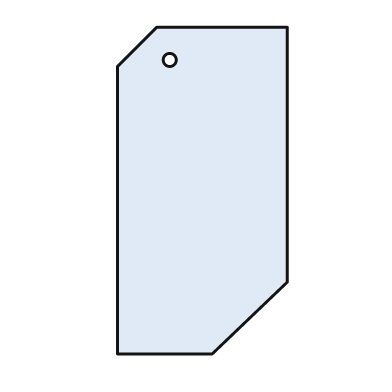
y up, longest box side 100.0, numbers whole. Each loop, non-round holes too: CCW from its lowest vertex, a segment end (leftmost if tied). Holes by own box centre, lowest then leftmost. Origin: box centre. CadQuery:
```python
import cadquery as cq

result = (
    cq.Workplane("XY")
    .moveTo(-26.0, -50.0)
    .lineTo(3.0, -50.0)
    .lineTo(26.0, -28.0)
    .lineTo(26.0, 50.0)
    .lineTo(-14.0, 50.0)
    .lineTo(-26.0, 38.0)
    .close()
    .moveTo(-10.0, 40.0)
    .circle(2.0)
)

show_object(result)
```